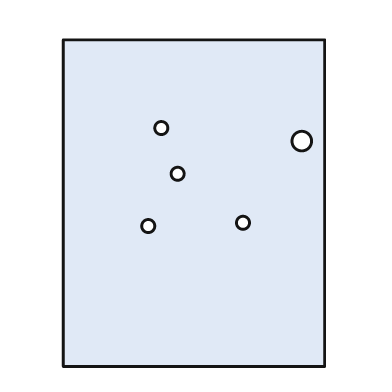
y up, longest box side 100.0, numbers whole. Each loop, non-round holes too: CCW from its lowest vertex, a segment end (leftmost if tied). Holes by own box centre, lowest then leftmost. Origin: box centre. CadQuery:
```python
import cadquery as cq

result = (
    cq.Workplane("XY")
    .moveTo(-40.0, -50.0)
    .lineTo(40.0, -50.0)
    .lineTo(40.0, 50.0)
    .lineTo(-40.0, 50.0)
    .close()
    .moveTo(-14.0, -7.0)
    .circle(2.0)
    .moveTo(15.0, -6.0)
    .circle(2.0)
    .moveTo(-5.0, 9.0)
    .circle(2.0)
    .moveTo(33.0, 19.0)
    .circle(3.0)
    .moveTo(-10.0, 23.0)
    .circle(2.0)
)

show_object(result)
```